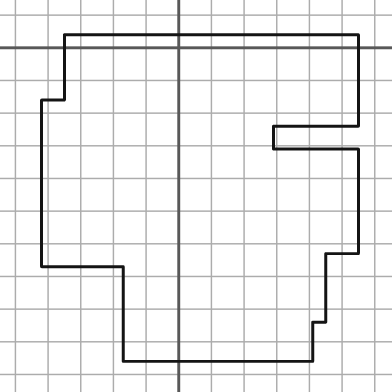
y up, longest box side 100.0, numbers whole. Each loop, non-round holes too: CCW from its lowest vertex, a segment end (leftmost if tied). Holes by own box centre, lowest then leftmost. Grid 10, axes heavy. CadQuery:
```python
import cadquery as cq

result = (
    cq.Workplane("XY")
    .moveTo(-17.0, -96.0)
    .lineTo(41.0, -96.0)
    .lineTo(41.0, -84.0)
    .lineTo(45.0, -84.0)
    .lineTo(45.0, -63.0)
    .lineTo(55.0, -63.0)
    .lineTo(55.0, -31.0)
    .lineTo(29.0, -31.0)
    .lineTo(29.0, -24.0)
    .lineTo(55.0, -24.0)
    .lineTo(55.0, 4.0)
    .lineTo(-35.0, 4.0)
    .lineTo(-35.0, -16.0)
    .lineTo(-42.0, -16.0)
    .lineTo(-42.0, -67.0)
    .lineTo(-17.0, -67.0)
    .close()
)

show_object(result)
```